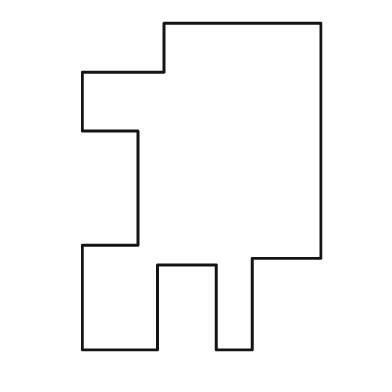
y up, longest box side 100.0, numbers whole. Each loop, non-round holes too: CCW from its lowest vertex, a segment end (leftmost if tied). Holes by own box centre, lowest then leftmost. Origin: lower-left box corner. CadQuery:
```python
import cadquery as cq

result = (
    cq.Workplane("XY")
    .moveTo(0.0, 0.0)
    .lineTo(23.0, 0.0)
    .lineTo(23.0, 26.0)
    .lineTo(41.0, 26.0)
    .lineTo(41.0, 0.0)
    .lineTo(52.0, 0.0)
    .lineTo(52.0, 28.0)
    .lineTo(73.0, 28.0)
    .lineTo(73.0, 100.0)
    .lineTo(25.0, 100.0)
    .lineTo(25.0, 85.0)
    .lineTo(0.0, 85.0)
    .lineTo(0.0, 67.0)
    .lineTo(17.0, 67.0)
    .lineTo(17.0, 32.0)
    .lineTo(0.0, 32.0)
    .close()
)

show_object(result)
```